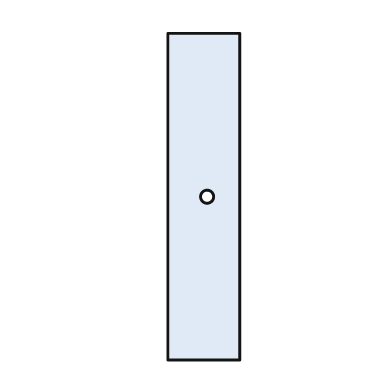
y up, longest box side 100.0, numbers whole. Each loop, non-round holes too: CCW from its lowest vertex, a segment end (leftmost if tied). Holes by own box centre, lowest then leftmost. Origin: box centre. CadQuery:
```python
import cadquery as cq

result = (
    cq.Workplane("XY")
    .moveTo(-11.0, -50.0)
    .lineTo(11.0, -50.0)
    .lineTo(11.0, 50.0)
    .lineTo(-11.0, 50.0)
    .close()
    .moveTo(1.0, 0.0)
    .circle(2.0)
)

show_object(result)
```